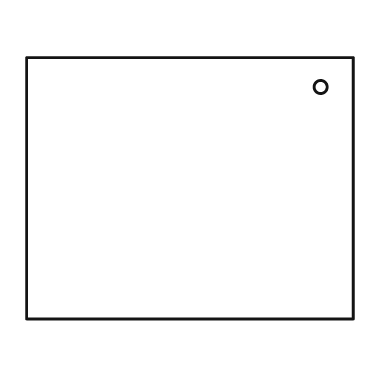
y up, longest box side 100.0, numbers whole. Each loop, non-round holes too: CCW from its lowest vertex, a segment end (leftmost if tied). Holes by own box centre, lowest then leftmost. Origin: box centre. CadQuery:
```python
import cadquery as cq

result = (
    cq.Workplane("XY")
    .moveTo(-50.0, -40.0)
    .lineTo(50.0, -40.0)
    .lineTo(50.0, 40.0)
    .lineTo(-50.0, 40.0)
    .close()
    .moveTo(40.0, 31.0)
    .circle(2.0)
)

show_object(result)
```